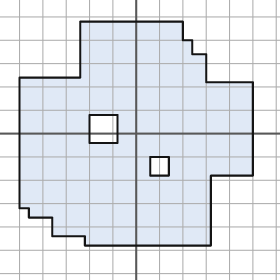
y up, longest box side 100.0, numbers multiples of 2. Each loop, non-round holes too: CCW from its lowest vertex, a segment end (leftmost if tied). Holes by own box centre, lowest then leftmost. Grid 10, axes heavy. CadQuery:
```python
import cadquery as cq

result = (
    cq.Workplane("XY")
    .moveTo(-22.0, -48.0)
    .lineTo(32.0, -48.0)
    .lineTo(32.0, -18.0)
    .lineTo(50.0, -18.0)
    .lineTo(50.0, 22.0)
    .lineTo(30.0, 22.0)
    .lineTo(30.0, 34.0)
    .lineTo(24.0, 34.0)
    .lineTo(24.0, 40.0)
    .lineTo(20.0, 40.0)
    .lineTo(20.0, 48.0)
    .lineTo(-24.0, 48.0)
    .lineTo(-24.0, 24.0)
    .lineTo(-50.0, 24.0)
    .lineTo(-50.0, -32.0)
    .lineTo(-46.0, -32.0)
    .lineTo(-46.0, -36.0)
    .lineTo(-36.0, -36.0)
    .lineTo(-36.0, -44.0)
    .lineTo(-22.0, -44.0)
    .close()
    .moveTo(6.0, -18.0)
    .lineTo(14.0, -18.0)
    .lineTo(14.0, -10.0)
    .lineTo(6.0, -10.0)
    .close()
    .moveTo(-20.0, -4.0)
    .lineTo(-8.0, -4.0)
    .lineTo(-8.0, 8.0)
    .lineTo(-20.0, 8.0)
    .close()
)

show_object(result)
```